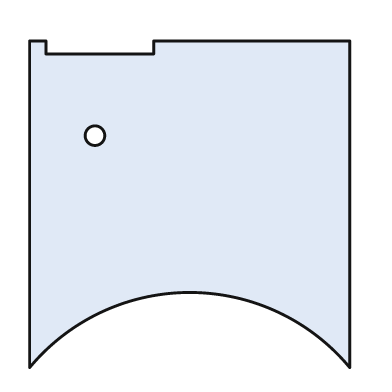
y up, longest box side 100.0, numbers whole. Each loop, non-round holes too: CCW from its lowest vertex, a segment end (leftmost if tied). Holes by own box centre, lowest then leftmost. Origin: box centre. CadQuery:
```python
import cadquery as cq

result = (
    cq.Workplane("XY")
    .moveTo(-49.0, -50.0)
    .threePointArc((0.0, -27.0), (49.0, -50.0))
    .lineTo(49.0, 50.0)
    .lineTo(-11.0, 50.0)
    .lineTo(-11.0, 46.0)
    .lineTo(-44.0, 46.0)
    .lineTo(-44.0, 50.0)
    .lineTo(-49.0, 50.0)
    .close()
    .moveTo(-29.0, 21.0)
    .circle(3.0)
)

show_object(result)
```